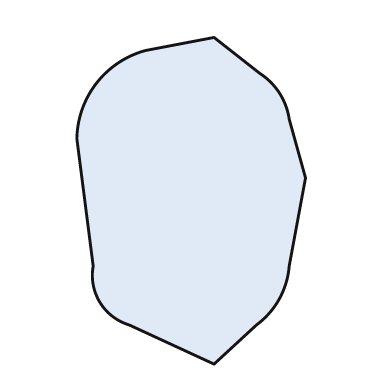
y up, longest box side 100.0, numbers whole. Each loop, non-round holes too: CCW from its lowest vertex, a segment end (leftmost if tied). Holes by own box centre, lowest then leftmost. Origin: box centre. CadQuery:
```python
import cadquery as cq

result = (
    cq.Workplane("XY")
    .moveTo(7.0, -50.0)
    .lineTo(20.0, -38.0)
    .threePointArc((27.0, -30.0), (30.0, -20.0))
    .lineTo(35.0, 7.0)
    .lineTo(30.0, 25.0)
    .threePointArc((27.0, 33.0), (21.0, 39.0))
    .lineTo(7.0, 50.0)
    .lineTo(-14.0, 46.0)
    .threePointArc((-29.0, 36.0), (-35.0, 19.0))
    .lineTo(-30.0, -20.0)
    .threePointArc((-28.0, -31.0), (-19.0, -38.0))
    .close()
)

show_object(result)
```